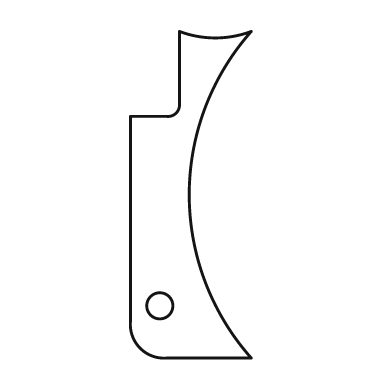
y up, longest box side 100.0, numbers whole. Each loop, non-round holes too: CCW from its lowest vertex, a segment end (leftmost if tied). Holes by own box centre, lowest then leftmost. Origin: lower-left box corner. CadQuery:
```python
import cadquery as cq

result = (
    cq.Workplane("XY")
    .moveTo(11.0, 0.0)
    .lineTo(37.0, 0.0)
    .threePointArc((18.0, 50.0), (37.0, 100.0))
    .threePointArc((26.0, 98.0), (15.0, 100.0))
    .lineTo(15.0, 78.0)
    .threePointArc((14.0, 75.0), (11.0, 74.0))
    .lineTo(0.0, 74.0)
    .lineTo(0.0, 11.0)
    .threePointArc((3.0, 3.0), (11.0, 0.0))
    .close()
    .moveTo(9.0, 16.0)
    .circle(4.0)
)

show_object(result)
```